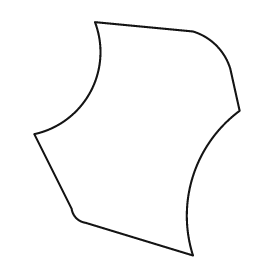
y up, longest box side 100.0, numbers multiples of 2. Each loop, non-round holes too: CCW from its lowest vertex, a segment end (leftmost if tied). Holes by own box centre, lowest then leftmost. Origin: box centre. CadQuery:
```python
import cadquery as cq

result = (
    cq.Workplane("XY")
    .moveTo(24.0, -50.0)
    .threePointArc((24.0, -16.0), (44.0, 12.0))
    .lineTo(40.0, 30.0)
    .threePointArc((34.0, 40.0), (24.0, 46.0))
    .lineTo(-18.0, 50.0)
    .threePointArc((-20.0, 20.0), (-44.0, 2.0))
    .lineTo(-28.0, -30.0)
    .threePointArc((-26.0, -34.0), (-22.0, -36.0))
    .close()
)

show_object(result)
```